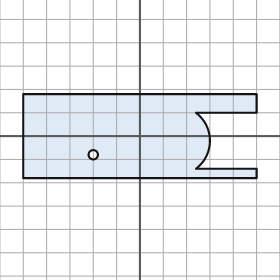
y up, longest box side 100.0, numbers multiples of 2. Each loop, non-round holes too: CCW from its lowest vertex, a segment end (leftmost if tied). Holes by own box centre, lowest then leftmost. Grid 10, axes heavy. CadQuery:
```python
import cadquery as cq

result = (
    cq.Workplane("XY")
    .moveTo(-50.0, -18.0)
    .lineTo(50.0, -18.0)
    .lineTo(50.0, -14.0)
    .lineTo(24.0, -14.0)
    .threePointArc((30.0, -2.0), (24.0, 10.0))
    .lineTo(50.0, 10.0)
    .lineTo(50.0, 18.0)
    .lineTo(-50.0, 18.0)
    .close()
    .moveTo(-20.0, -8.0)
    .circle(2.0)
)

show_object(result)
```